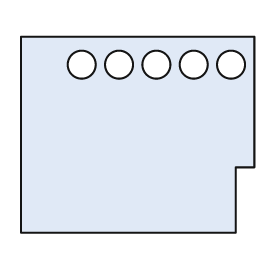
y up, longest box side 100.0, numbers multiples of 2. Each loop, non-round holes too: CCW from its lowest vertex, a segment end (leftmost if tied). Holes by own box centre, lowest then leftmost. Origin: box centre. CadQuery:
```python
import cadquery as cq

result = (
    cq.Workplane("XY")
    .moveTo(-50.0, -42.0)
    .lineTo(42.0, -42.0)
    .lineTo(42.0, -14.0)
    .lineTo(50.0, -14.0)
    .lineTo(50.0, 42.0)
    .lineTo(-50.0, 42.0)
    .close()
    .moveTo(-24.0, 30.0)
    .circle(6.0)
    .moveTo(-8.0, 30.0)
    .circle(6.0)
    .moveTo(8.0, 30.0)
    .circle(6.0)
    .moveTo(24.0, 30.0)
    .circle(6.0)
    .moveTo(40.0, 30.0)
    .circle(6.0)
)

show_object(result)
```